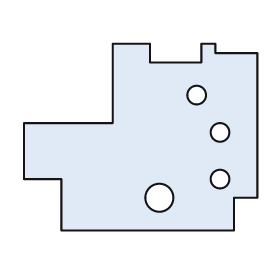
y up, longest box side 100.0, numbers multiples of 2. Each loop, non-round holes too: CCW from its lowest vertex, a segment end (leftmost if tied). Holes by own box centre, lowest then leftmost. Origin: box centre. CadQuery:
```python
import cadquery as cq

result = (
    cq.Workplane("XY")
    .moveTo(-34.0, -40.0)
    .lineTo(40.0, -40.0)
    .lineTo(40.0, -26.0)
    .lineTo(50.0, -26.0)
    .lineTo(50.0, 36.0)
    .lineTo(32.0, 36.0)
    .lineTo(32.0, 40.0)
    .lineTo(26.0, 40.0)
    .lineTo(26.0, 32.0)
    .lineTo(4.0, 32.0)
    .lineTo(4.0, 40.0)
    .lineTo(-12.0, 40.0)
    .lineTo(-12.0, 6.0)
    .lineTo(-50.0, 6.0)
    .lineTo(-50.0, -18.0)
    .lineTo(-34.0, -18.0)
    .close()
    .moveTo(8.0, -26.0)
    .circle(6.0)
    .moveTo(34.0, -18.0)
    .circle(4.0)
    .moveTo(34.0, 2.0)
    .circle(4.0)
    .moveTo(24.0, 18.0)
    .circle(4.0)
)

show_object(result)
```